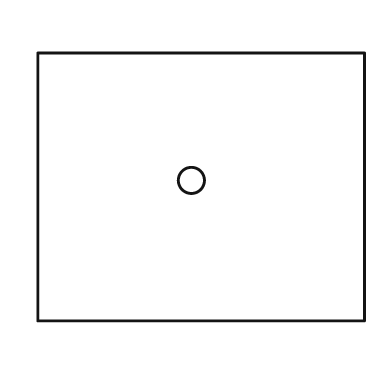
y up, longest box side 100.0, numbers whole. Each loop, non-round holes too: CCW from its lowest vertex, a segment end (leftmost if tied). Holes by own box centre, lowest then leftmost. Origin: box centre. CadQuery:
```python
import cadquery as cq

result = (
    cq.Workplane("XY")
    .moveTo(-50.0, -41.0)
    .lineTo(50.0, -41.0)
    .lineTo(50.0, 41.0)
    .lineTo(-50.0, 41.0)
    .close()
    .moveTo(-3.0, 2.0)
    .circle(4.0)
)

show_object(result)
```